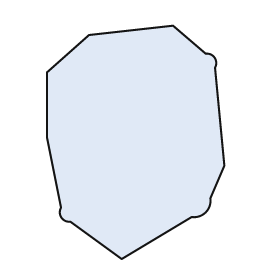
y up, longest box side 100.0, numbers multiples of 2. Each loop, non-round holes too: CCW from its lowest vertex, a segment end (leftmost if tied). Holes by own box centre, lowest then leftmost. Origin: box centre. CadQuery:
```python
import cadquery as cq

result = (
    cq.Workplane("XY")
    .moveTo(-6.0, -50.0)
    .lineTo(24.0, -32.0)
    .threePointArc((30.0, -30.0), (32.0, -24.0))
    .lineTo(38.0, -10.0)
    .lineTo(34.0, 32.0)
    .threePointArc((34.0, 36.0), (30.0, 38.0))
    .lineTo(16.0, 50.0)
    .lineTo(-20.0, 46.0)
    .lineTo(-38.0, 30.0)
    .lineTo(-38.0, 2.0)
    .lineTo(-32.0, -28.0)
    .threePointArc((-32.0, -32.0), (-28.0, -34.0))
    .close()
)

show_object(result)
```